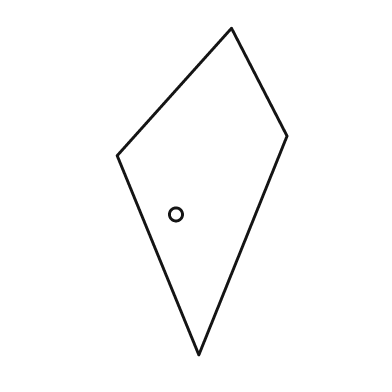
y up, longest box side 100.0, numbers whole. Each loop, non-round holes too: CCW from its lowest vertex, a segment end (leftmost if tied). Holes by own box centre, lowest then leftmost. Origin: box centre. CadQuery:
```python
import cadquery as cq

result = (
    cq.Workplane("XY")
    .moveTo(-1.0, -50.0)
    .lineTo(26.0, 17.0)
    .lineTo(9.0, 50.0)
    .lineTo(-26.0, 11.0)
    .close()
    .moveTo(-8.0, -7.0)
    .circle(2.0)
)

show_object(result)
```